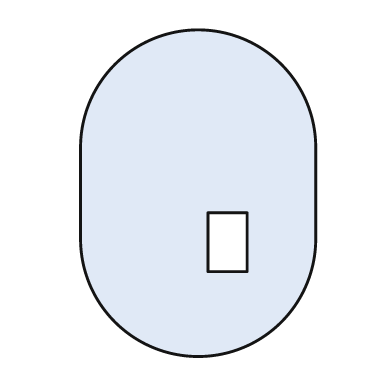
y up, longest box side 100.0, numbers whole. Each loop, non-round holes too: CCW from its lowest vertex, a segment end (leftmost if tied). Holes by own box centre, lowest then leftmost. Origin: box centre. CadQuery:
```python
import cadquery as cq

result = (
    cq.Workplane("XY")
    .moveTo(-36.0, -14.0)
    .threePointArc((0.0, -50.0), (36.0, -14.0))
    .lineTo(36.0, 14.0)
    .threePointArc((0.0, 50.0), (-36.0, 14.0))
    .close()
    .moveTo(3.0, -24.0)
    .lineTo(15.0, -24.0)
    .lineTo(15.0, -6.0)
    .lineTo(3.0, -6.0)
    .close()
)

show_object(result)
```